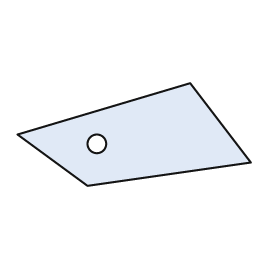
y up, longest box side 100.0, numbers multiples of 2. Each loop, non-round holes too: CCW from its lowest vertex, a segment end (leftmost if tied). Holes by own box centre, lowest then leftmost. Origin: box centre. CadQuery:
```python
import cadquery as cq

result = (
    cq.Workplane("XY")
    .moveTo(-20.0, -22.0)
    .lineTo(50.0, -12.0)
    .lineTo(24.0, 22.0)
    .lineTo(-50.0, 0.0)
    .close()
    .moveTo(-16.0, -4.0)
    .circle(4.0)
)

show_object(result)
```